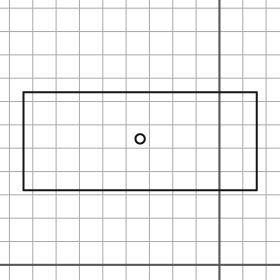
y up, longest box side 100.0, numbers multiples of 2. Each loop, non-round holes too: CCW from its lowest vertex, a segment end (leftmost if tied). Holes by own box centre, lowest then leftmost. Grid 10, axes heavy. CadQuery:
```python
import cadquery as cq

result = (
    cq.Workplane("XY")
    .moveTo(-84.0, 32.0)
    .lineTo(16.0, 32.0)
    .lineTo(16.0, 74.0)
    .lineTo(-84.0, 74.0)
    .close()
    .moveTo(-34.0, 54.0)
    .circle(2.0)
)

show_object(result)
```